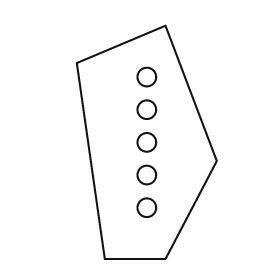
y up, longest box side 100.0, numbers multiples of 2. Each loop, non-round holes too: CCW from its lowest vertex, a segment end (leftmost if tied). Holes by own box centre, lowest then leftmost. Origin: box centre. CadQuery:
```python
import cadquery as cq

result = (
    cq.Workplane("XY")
    .moveTo(-18.0, -50.0)
    .lineTo(8.0, -50.0)
    .lineTo(30.0, -8.0)
    .lineTo(8.0, 50.0)
    .lineTo(-30.0, 34.0)
    .close()
    .moveTo(0.0, -28.0)
    .circle(4.0)
    .moveTo(0.0, -14.0)
    .circle(4.0)
    .moveTo(0.0, 0.0)
    .circle(4.0)
    .moveTo(0.0, 14.0)
    .circle(4.0)
    .moveTo(0.0, 28.0)
    .circle(4.0)
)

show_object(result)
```